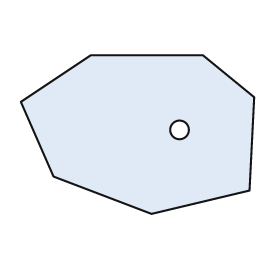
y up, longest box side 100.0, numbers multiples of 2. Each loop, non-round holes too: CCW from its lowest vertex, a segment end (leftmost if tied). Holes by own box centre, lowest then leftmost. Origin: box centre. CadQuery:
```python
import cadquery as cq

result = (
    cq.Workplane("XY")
    .moveTo(6.0, -34.0)
    .lineTo(48.0, -24.0)
    .lineTo(50.0, 16.0)
    .lineTo(28.0, 34.0)
    .lineTo(-20.0, 34.0)
    .lineTo(-50.0, 14.0)
    .lineTo(-36.0, -18.0)
    .close()
    .moveTo(18.0, 2.0)
    .circle(4.0)
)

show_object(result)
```